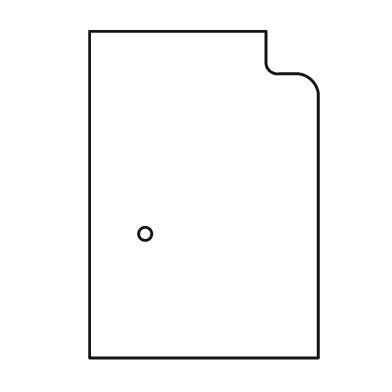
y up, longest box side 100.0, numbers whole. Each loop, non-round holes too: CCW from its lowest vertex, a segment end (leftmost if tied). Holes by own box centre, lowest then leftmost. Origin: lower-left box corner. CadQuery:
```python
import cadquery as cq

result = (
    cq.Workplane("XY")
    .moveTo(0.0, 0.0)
    .lineTo(70.0, 0.0)
    .lineTo(70.0, 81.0)
    .threePointArc((68.0, 85.0), (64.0, 87.0))
    .lineTo(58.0, 87.0)
    .threePointArc((55.0, 88.0), (54.0, 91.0))
    .lineTo(54.0, 100.0)
    .lineTo(0.0, 100.0)
    .close()
    .moveTo(17.0, 38.0)
    .circle(2.0)
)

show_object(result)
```